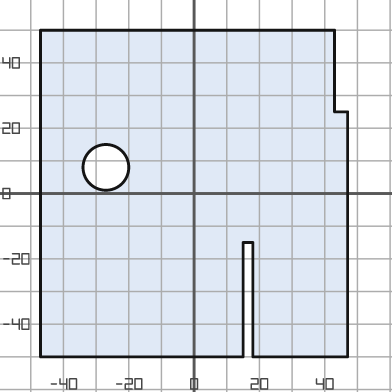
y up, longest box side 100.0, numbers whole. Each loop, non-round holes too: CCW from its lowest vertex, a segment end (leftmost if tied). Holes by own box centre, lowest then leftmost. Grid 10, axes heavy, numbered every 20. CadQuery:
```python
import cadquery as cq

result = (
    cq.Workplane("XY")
    .moveTo(-47.0, -50.0)
    .lineTo(15.0, -50.0)
    .lineTo(15.0, -15.0)
    .lineTo(18.0, -15.0)
    .lineTo(18.0, -50.0)
    .lineTo(47.0, -50.0)
    .lineTo(47.0, 25.0)
    .lineTo(43.0, 25.0)
    .lineTo(43.0, 50.0)
    .lineTo(-47.0, 50.0)
    .close()
    .moveTo(-27.0, 8.0)
    .circle(7.0)
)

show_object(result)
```